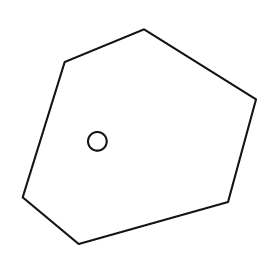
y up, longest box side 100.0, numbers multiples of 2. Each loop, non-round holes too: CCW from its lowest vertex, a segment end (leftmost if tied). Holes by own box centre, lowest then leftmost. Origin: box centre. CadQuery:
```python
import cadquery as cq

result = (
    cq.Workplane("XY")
    .moveTo(-26.0, -46.0)
    .lineTo(38.0, -28.0)
    .lineTo(50.0, 16.0)
    .lineTo(2.0, 46.0)
    .lineTo(-32.0, 32.0)
    .lineTo(-50.0, -26.0)
    .close()
    .moveTo(-18.0, -2.0)
    .circle(4.0)
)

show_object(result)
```